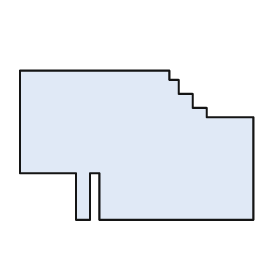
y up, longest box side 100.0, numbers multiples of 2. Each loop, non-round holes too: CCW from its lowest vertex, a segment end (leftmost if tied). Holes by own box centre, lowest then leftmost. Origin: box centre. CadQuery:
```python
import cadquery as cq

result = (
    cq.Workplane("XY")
    .moveTo(-26.0, -32.0)
    .lineTo(-20.0, -32.0)
    .lineTo(-20.0, -12.0)
    .lineTo(-16.0, -12.0)
    .lineTo(-16.0, -32.0)
    .lineTo(50.0, -32.0)
    .lineTo(50.0, 12.0)
    .lineTo(30.0, 12.0)
    .lineTo(30.0, 16.0)
    .lineTo(24.0, 16.0)
    .lineTo(24.0, 22.0)
    .lineTo(18.0, 22.0)
    .lineTo(18.0, 28.0)
    .lineTo(14.0, 28.0)
    .lineTo(14.0, 32.0)
    .lineTo(-50.0, 32.0)
    .lineTo(-50.0, -12.0)
    .lineTo(-26.0, -12.0)
    .close()
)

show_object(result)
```